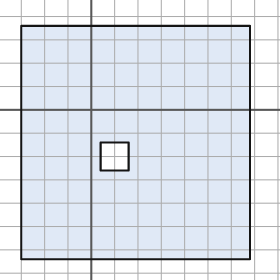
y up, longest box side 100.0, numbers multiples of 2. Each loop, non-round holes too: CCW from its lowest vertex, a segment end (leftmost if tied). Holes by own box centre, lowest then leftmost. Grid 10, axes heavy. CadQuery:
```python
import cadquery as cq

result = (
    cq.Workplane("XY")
    .moveTo(-30.0, -64.0)
    .lineTo(68.0, -64.0)
    .lineTo(68.0, 36.0)
    .lineTo(-30.0, 36.0)
    .close()
    .moveTo(4.0, -26.0)
    .lineTo(16.0, -26.0)
    .lineTo(16.0, -14.0)
    .lineTo(4.0, -14.0)
    .close()
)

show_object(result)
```